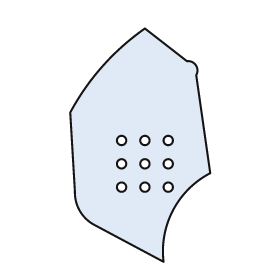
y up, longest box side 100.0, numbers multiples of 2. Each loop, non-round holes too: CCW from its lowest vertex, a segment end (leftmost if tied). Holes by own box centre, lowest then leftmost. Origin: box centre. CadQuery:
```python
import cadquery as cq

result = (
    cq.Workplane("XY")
    .moveTo(10.0, -50.0)
    .threePointArc((14.0, -28.0), (30.0, -12.0))
    .lineTo(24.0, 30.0)
    .threePointArc((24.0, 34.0), (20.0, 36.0))
    .lineTo(2.0, 50.0)
    .threePointArc((-16.0, 34.0), (-30.0, 14.0))
    .lineTo(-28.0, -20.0)
    .threePointArc((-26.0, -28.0), (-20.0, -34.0))
    .close()
    .moveTo(-8.0, -18.0)
    .circle(2.0)
    .moveTo(2.0, -18.0)
    .circle(2.0)
    .moveTo(12.0, -18.0)
    .circle(2.0)
    .moveTo(-8.0, -8.0)
    .circle(2.0)
    .moveTo(2.0, -8.0)
    .circle(2.0)
    .moveTo(12.0, -8.0)
    .circle(2.0)
    .moveTo(-8.0, 2.0)
    .circle(2.0)
    .moveTo(2.0, 2.0)
    .circle(2.0)
    .moveTo(12.0, 2.0)
    .circle(2.0)
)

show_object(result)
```